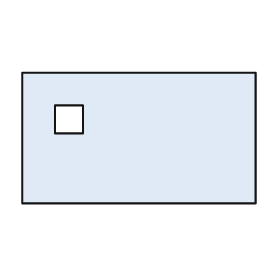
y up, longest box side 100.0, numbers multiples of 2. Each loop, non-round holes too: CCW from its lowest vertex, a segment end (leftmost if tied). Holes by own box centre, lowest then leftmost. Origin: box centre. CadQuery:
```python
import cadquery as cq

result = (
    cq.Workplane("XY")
    .moveTo(-50.0, -28.0)
    .lineTo(50.0, -28.0)
    .lineTo(50.0, 28.0)
    .lineTo(-50.0, 28.0)
    .close()
    .moveTo(-36.0, 2.0)
    .lineTo(-24.0, 2.0)
    .lineTo(-24.0, 14.0)
    .lineTo(-36.0, 14.0)
    .close()
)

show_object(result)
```